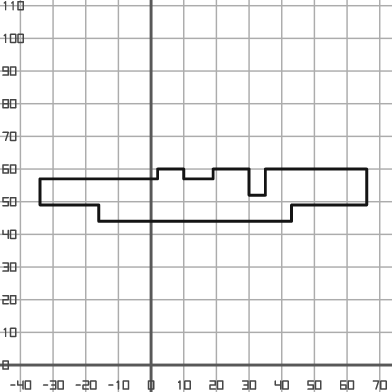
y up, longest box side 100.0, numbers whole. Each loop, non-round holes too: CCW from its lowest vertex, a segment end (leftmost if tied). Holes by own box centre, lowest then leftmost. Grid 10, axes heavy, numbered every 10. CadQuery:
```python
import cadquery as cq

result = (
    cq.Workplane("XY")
    .moveTo(-16.0, 44.0)
    .lineTo(43.0, 44.0)
    .lineTo(43.0, 49.0)
    .lineTo(66.0, 49.0)
    .lineTo(66.0, 60.0)
    .lineTo(35.0, 60.0)
    .lineTo(35.0, 52.0)
    .lineTo(30.0, 52.0)
    .lineTo(30.0, 60.0)
    .lineTo(19.0, 60.0)
    .lineTo(19.0, 57.0)
    .lineTo(10.0, 57.0)
    .lineTo(10.0, 60.0)
    .lineTo(2.0, 60.0)
    .lineTo(2.0, 57.0)
    .lineTo(-34.0, 57.0)
    .lineTo(-34.0, 49.0)
    .lineTo(-16.0, 49.0)
    .close()
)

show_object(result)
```